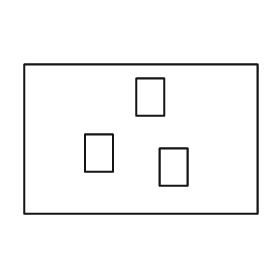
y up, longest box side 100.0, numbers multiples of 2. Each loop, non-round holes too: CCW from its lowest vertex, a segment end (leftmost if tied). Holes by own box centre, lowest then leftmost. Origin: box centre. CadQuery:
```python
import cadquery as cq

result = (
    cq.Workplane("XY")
    .moveTo(-50.0, -32.0)
    .lineTo(50.0, -32.0)
    .lineTo(50.0, 32.0)
    .lineTo(-50.0, 32.0)
    .close()
    .moveTo(8.0, -20.0)
    .lineTo(20.0, -20.0)
    .lineTo(20.0, -4.0)
    .lineTo(8.0, -4.0)
    .close()
    .moveTo(-24.0, -14.0)
    .lineTo(-12.0, -14.0)
    .lineTo(-12.0, 2.0)
    .lineTo(-24.0, 2.0)
    .close()
    .moveTo(-2.0, 10.0)
    .lineTo(10.0, 10.0)
    .lineTo(10.0, 26.0)
    .lineTo(-2.0, 26.0)
    .close()
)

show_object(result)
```